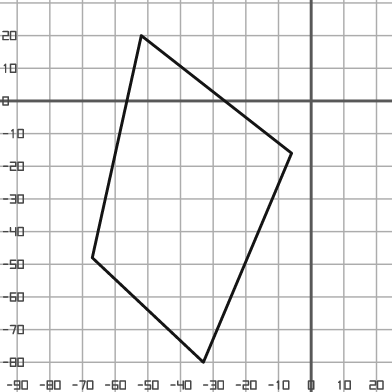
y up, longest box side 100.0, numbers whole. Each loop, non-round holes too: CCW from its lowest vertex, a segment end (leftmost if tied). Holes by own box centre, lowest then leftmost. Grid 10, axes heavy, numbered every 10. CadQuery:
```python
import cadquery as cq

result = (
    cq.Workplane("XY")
    .moveTo(-33.0, -80.0)
    .lineTo(-6.0, -16.0)
    .lineTo(-52.0, 20.0)
    .lineTo(-67.0, -48.0)
    .close()
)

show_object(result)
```